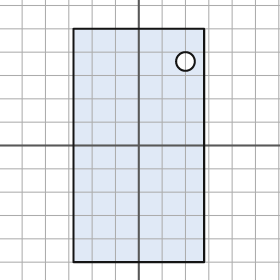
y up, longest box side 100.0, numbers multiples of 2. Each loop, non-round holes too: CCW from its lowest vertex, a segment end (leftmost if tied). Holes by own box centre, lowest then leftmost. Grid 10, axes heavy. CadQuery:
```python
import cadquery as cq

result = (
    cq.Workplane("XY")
    .moveTo(-28.0, -50.0)
    .lineTo(28.0, -50.0)
    .lineTo(28.0, 50.0)
    .lineTo(-28.0, 50.0)
    .close()
    .moveTo(20.0, 36.0)
    .circle(4.0)
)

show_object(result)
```